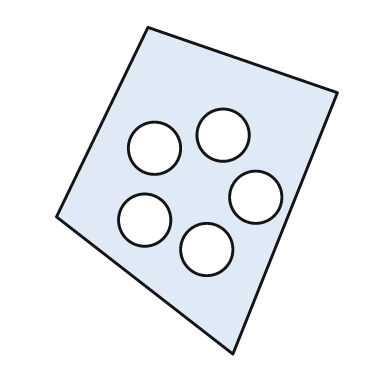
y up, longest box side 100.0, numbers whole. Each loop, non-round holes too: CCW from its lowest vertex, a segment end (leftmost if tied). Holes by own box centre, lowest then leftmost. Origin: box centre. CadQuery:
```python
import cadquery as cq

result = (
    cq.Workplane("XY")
    .moveTo(11.0, -50.0)
    .lineTo(43.0, 30.0)
    .lineTo(-15.0, 50.0)
    .lineTo(-43.0, -8.0)
    .close()
    .moveTo(3.0, -18.0)
    .circle(8.0)
    .moveTo(-16.0, -9.0)
    .circle(8.0)
    .moveTo(18.0, -2.0)
    .circle(8.0)
    .moveTo(-13.0, 13.0)
    .circle(8.0)
    .moveTo(8.0, 17.0)
    .circle(8.0)
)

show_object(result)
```